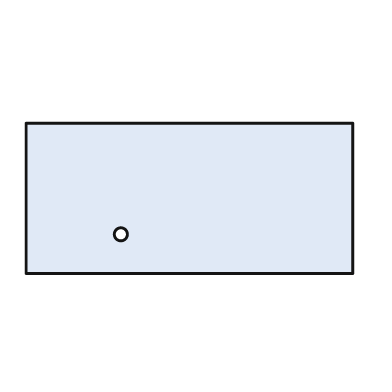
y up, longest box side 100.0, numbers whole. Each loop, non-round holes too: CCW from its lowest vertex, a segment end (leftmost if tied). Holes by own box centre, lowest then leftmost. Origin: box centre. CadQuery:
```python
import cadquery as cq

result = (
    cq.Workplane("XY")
    .moveTo(-50.0, -23.0)
    .lineTo(50.0, -23.0)
    .lineTo(50.0, 23.0)
    .lineTo(-50.0, 23.0)
    .close()
    .moveTo(-21.0, -11.0)
    .circle(2.0)
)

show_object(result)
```